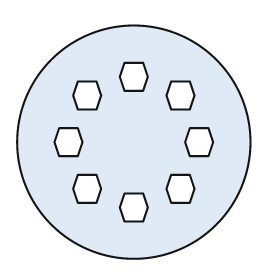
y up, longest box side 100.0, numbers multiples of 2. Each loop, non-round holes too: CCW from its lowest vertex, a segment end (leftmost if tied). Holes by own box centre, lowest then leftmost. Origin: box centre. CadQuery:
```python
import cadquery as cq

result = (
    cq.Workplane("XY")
    .moveTo(0.0, 0.0)
    .circle(50.0)
    .moveTo(-4.0, -34.0)
    .lineTo(4.0, -34.0)
    .lineTo(6.0, -28.0)
    .lineTo(4.0, -22.0)
    .lineTo(-4.0, -22.0)
    .lineTo(-6.0, -28.0)
    .close()
    .moveTo(-24.0, -26.0)
    .lineTo(-16.0, -26.0)
    .lineTo(-14.0, -20.0)
    .lineTo(-16.0, -14.0)
    .lineTo(-24.0, -14.0)
    .lineTo(-26.0, -20.0)
    .close()
    .moveTo(16.0, -26.0)
    .lineTo(24.0, -26.0)
    .lineTo(26.0, -20.0)
    .lineTo(24.0, -14.0)
    .lineTo(16.0, -14.0)
    .lineTo(14.0, -20.0)
    .close()
    .moveTo(-32.0, -6.0)
    .lineTo(-24.0, -6.0)
    .lineTo(-22.0, 0.0)
    .lineTo(-24.0, 6.0)
    .lineTo(-32.0, 6.0)
    .lineTo(-34.0, 0.0)
    .close()
    .moveTo(24.0, -6.0)
    .lineTo(32.0, -6.0)
    .lineTo(34.0, 0.0)
    .lineTo(32.0, 6.0)
    .lineTo(24.0, 6.0)
    .lineTo(22.0, 0.0)
    .close()
    .moveTo(-24.0, 14.0)
    .lineTo(-16.0, 14.0)
    .lineTo(-14.0, 20.0)
    .lineTo(-16.0, 26.0)
    .lineTo(-24.0, 26.0)
    .lineTo(-26.0, 20.0)
    .close()
    .moveTo(16.0, 14.0)
    .lineTo(24.0, 14.0)
    .lineTo(26.0, 20.0)
    .lineTo(24.0, 26.0)
    .lineTo(16.0, 26.0)
    .lineTo(14.0, 20.0)
    .close()
    .moveTo(-4.0, 22.0)
    .lineTo(4.0, 22.0)
    .lineTo(6.0, 28.0)
    .lineTo(4.0, 34.0)
    .lineTo(-4.0, 34.0)
    .lineTo(-6.0, 28.0)
    .close()
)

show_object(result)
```